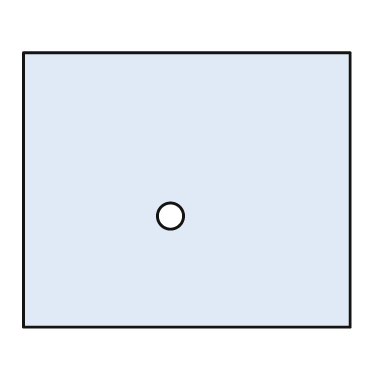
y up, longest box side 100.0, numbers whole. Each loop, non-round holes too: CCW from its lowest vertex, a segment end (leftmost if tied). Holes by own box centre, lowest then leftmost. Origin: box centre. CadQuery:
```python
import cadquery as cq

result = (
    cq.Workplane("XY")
    .moveTo(-50.0, -42.0)
    .lineTo(50.0, -42.0)
    .lineTo(50.0, 42.0)
    .lineTo(-50.0, 42.0)
    .close()
    .moveTo(-5.0, -8.0)
    .circle(4.0)
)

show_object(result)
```